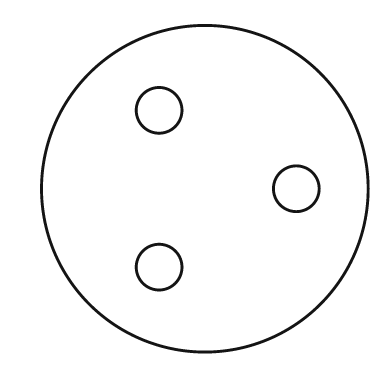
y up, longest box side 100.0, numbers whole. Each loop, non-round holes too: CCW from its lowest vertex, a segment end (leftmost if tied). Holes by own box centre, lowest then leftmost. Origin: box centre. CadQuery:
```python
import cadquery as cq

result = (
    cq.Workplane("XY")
    .moveTo(0.0, 0.0)
    .circle(50.0)
    .moveTo(-14.0, -24.0)
    .circle(7.0)
    .moveTo(28.0, 0.0)
    .circle(7.0)
    .moveTo(-14.0, 24.0)
    .circle(7.0)
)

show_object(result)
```